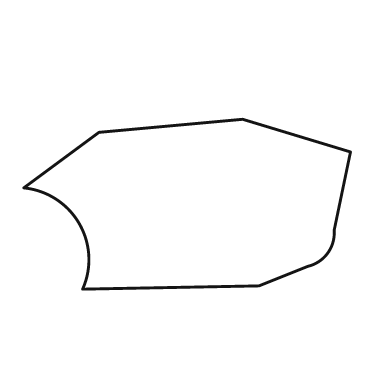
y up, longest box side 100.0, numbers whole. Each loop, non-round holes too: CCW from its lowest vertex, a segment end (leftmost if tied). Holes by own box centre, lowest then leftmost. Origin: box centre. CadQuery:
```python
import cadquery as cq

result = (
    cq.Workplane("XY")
    .moveTo(-32.0, -26.0)
    .lineTo(22.0, -25.0)
    .lineTo(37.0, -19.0)
    .threePointArc((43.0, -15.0), (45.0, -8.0))
    .lineTo(50.0, 16.0)
    .lineTo(17.0, 26.0)
    .lineTo(-27.0, 22.0)
    .lineTo(-50.0, 5.0)
    .threePointArc((-33.0, -6.0), (-32.0, -26.0))
    .close()
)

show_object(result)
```